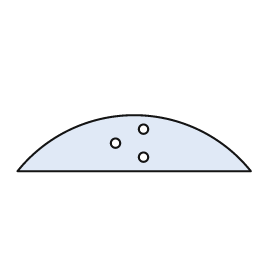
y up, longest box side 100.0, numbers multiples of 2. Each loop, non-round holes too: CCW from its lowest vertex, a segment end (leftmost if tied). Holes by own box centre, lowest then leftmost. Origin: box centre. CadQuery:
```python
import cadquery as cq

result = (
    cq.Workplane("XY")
    .moveTo(-50.0, -12.0)
    .lineTo(50.0, -12.0)
    .threePointArc((0.0, 12.0), (-50.0, -12.0))
    .close()
    .moveTo(4.0, -6.0)
    .circle(2.0)
    .moveTo(-8.0, 0.0)
    .circle(2.0)
    .moveTo(4.0, 6.0)
    .circle(2.0)
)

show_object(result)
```